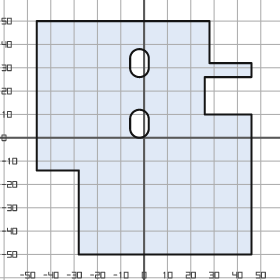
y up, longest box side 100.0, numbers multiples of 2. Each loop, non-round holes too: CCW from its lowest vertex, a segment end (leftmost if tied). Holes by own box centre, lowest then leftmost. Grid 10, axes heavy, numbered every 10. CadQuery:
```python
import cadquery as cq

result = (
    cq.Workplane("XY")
    .moveTo(-28.0, -50.0)
    .lineTo(46.0, -50.0)
    .lineTo(46.0, 10.0)
    .lineTo(26.0, 10.0)
    .lineTo(26.0, 26.0)
    .lineTo(46.0, 26.0)
    .lineTo(46.0, 32.0)
    .lineTo(28.0, 32.0)
    .lineTo(28.0, 50.0)
    .lineTo(-46.0, 50.0)
    .lineTo(-46.0, -14.0)
    .lineTo(-28.0, -14.0)
    .close()
    .moveTo(-6.0, 4.0)
    .threePointArc((-2.0, 0.0), (2.0, 4.0))
    .lineTo(2.0, 8.0)
    .threePointArc((-2.0, 12.0), (-6.0, 8.0))
    .close()
    .moveTo(-6.0, 30.0)
    .threePointArc((-2.0, 26.0), (2.0, 30.0))
    .lineTo(2.0, 34.0)
    .threePointArc((-2.0, 38.0), (-6.0, 34.0))
    .close()
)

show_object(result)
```